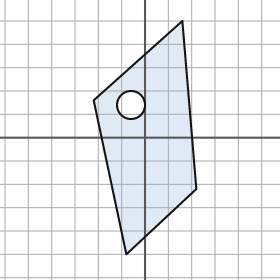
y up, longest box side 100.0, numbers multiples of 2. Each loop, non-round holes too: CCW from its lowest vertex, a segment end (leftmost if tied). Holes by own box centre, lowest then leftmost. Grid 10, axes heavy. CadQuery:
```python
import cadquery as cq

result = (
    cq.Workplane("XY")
    .moveTo(-8.0, -50.0)
    .lineTo(22.0, -22.0)
    .lineTo(16.0, 50.0)
    .lineTo(-22.0, 16.0)
    .close()
    .moveTo(-6.0, 14.0)
    .circle(6.0)
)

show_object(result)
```